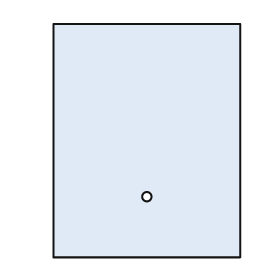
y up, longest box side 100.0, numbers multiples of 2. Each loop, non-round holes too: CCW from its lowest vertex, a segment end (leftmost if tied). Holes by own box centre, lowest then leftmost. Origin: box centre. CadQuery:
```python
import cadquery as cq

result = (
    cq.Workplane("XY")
    .moveTo(-40.0, -50.0)
    .lineTo(40.0, -50.0)
    .lineTo(40.0, 50.0)
    .lineTo(-40.0, 50.0)
    .close()
    .moveTo(0.0, -24.0)
    .circle(2.0)
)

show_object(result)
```